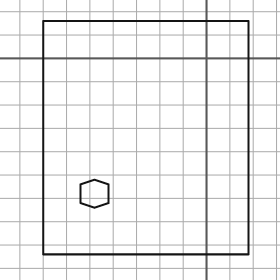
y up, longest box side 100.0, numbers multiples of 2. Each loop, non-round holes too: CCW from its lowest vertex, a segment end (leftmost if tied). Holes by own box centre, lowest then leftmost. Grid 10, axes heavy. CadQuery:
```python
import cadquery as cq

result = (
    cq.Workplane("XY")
    .moveTo(-70.0, -84.0)
    .lineTo(18.0, -84.0)
    .lineTo(18.0, 16.0)
    .lineTo(-70.0, 16.0)
    .close()
    .moveTo(-48.0, -64.0)
    .lineTo(-42.0, -62.0)
    .lineTo(-42.0, -54.0)
    .lineTo(-48.0, -52.0)
    .lineTo(-54.0, -54.0)
    .lineTo(-54.0, -62.0)
    .close()
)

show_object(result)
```